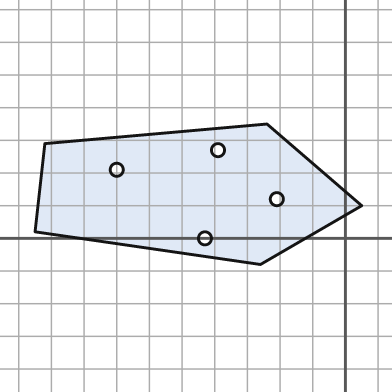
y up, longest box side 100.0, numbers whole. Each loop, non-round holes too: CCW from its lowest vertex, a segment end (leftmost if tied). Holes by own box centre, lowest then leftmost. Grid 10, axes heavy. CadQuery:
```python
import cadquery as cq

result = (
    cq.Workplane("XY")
    .moveTo(-26.0, -8.0)
    .lineTo(5.0, 10.0)
    .lineTo(-24.0, 35.0)
    .lineTo(-92.0, 29.0)
    .lineTo(-95.0, 2.0)
    .close()
    .moveTo(-43.0, 0.0)
    .circle(2.0)
    .moveTo(-21.0, 12.0)
    .circle(2.0)
    .moveTo(-70.0, 21.0)
    .circle(2.0)
    .moveTo(-39.0, 27.0)
    .circle(2.0)
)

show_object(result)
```